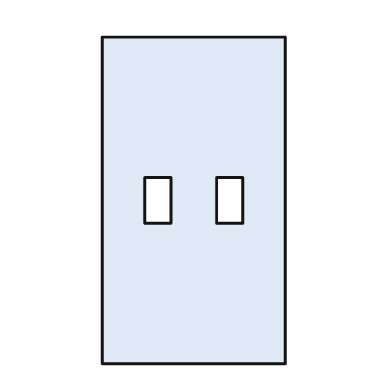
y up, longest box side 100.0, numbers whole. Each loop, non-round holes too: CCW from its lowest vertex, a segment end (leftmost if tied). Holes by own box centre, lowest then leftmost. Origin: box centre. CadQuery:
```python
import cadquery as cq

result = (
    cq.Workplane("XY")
    .moveTo(-28.0, -50.0)
    .lineTo(28.0, -50.0)
    .lineTo(28.0, 50.0)
    .lineTo(-28.0, 50.0)
    .close()
    .moveTo(-15.0, -7.0)
    .lineTo(-7.0, -7.0)
    .lineTo(-7.0, 7.0)
    .lineTo(-15.0, 7.0)
    .close()
    .moveTo(7.0, -7.0)
    .lineTo(15.0, -7.0)
    .lineTo(15.0, 7.0)
    .lineTo(7.0, 7.0)
    .close()
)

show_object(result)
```